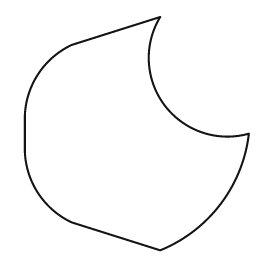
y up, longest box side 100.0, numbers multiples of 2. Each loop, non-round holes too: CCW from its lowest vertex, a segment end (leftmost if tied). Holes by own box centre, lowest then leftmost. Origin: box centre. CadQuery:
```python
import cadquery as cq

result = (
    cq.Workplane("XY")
    .moveTo(10.0, -50.0)
    .threePointArc((36.0, -30.0), (48.0, 0.0))
    .threePointArc((12.0, 12.0), (10.0, 50.0))
    .lineTo(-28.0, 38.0)
    .threePointArc((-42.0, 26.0), (-48.0, 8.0))
    .lineTo(-48.0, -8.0)
    .threePointArc((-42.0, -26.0), (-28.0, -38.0))
    .close()
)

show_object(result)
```